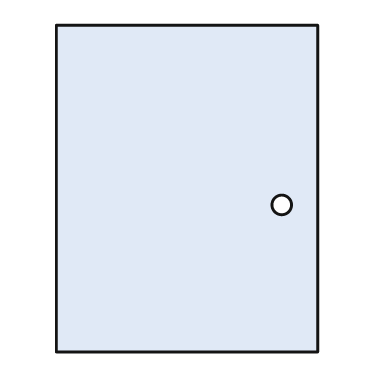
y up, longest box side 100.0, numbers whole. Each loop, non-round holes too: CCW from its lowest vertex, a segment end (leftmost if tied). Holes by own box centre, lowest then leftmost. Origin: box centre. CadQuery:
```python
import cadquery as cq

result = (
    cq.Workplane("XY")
    .moveTo(-40.0, -50.0)
    .lineTo(40.0, -50.0)
    .lineTo(40.0, 50.0)
    .lineTo(-40.0, 50.0)
    .close()
    .moveTo(29.0, -5.0)
    .circle(3.0)
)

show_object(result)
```